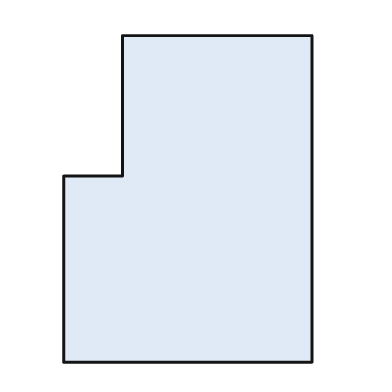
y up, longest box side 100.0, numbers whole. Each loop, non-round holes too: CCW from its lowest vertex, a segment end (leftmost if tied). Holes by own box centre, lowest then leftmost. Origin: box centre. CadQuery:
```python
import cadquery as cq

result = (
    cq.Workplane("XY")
    .moveTo(-38.0, -50.0)
    .lineTo(38.0, -50.0)
    .lineTo(38.0, 50.0)
    .lineTo(-20.0, 50.0)
    .lineTo(-20.0, 7.0)
    .lineTo(-38.0, 7.0)
    .close()
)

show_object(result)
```